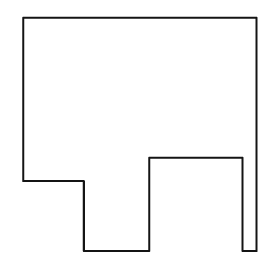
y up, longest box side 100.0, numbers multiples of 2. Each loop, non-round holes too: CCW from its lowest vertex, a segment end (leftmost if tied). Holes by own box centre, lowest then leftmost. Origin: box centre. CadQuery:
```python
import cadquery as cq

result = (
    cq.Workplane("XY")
    .moveTo(-24.0, -50.0)
    .lineTo(4.0, -50.0)
    .lineTo(4.0, -10.0)
    .lineTo(44.0, -10.0)
    .lineTo(44.0, -50.0)
    .lineTo(50.0, -50.0)
    .lineTo(50.0, 50.0)
    .lineTo(-50.0, 50.0)
    .lineTo(-50.0, -20.0)
    .lineTo(-24.0, -20.0)
    .close()
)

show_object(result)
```